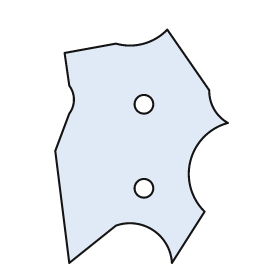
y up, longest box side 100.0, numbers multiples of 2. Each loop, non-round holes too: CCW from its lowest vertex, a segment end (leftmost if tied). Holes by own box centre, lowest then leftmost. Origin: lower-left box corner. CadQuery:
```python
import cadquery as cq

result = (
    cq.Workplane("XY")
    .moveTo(6.0, 0.0)
    .lineTo(26.0, 16.0)
    .threePointArc((42.0, 14.0), (50.0, 0.0))
    .lineTo(64.0, 22.0)
    .threePointArc((58.0, 44.0), (74.0, 60.0))
    .threePointArc((68.0, 66.0), (66.0, 74.0))
    .lineTo(48.0, 100.0)
    .threePointArc((38.0, 94.0), (26.0, 94.0))
    .lineTo(4.0, 90.0)
    .lineTo(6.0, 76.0)
    .threePointArc((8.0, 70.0), (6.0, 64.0))
    .lineTo(0.0, 48.0)
    .close()
    .moveTo(38.0, 32.0)
    .circle(4.0)
    .moveTo(38.0, 68.0)
    .circle(4.0)
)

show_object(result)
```